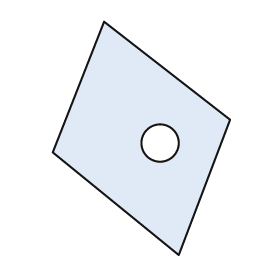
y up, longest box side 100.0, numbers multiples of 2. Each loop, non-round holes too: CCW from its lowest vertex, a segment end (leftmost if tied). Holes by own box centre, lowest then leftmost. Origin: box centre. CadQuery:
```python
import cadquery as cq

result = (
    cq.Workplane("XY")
    .moveTo(16.0, -50.0)
    .lineTo(38.0, 8.0)
    .lineTo(-16.0, 50.0)
    .lineTo(-38.0, -6.0)
    .close()
    .moveTo(8.0, -2.0)
    .circle(8.0)
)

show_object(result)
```